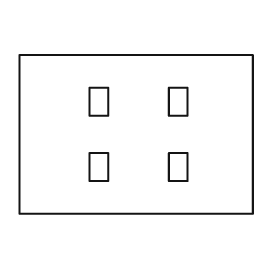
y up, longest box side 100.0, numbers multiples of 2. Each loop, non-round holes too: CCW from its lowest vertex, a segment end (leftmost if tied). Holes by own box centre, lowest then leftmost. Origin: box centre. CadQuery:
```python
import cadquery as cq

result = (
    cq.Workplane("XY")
    .moveTo(-50.0, -34.0)
    .lineTo(50.0, -34.0)
    .lineTo(50.0, 34.0)
    .lineTo(-50.0, 34.0)
    .close()
    .moveTo(-20.0, -20.0)
    .lineTo(-12.0, -20.0)
    .lineTo(-12.0, -8.0)
    .lineTo(-20.0, -8.0)
    .close()
    .moveTo(14.0, -20.0)
    .lineTo(22.0, -20.0)
    .lineTo(22.0, -8.0)
    .lineTo(14.0, -8.0)
    .close()
    .moveTo(-20.0, 8.0)
    .lineTo(-12.0, 8.0)
    .lineTo(-12.0, 20.0)
    .lineTo(-20.0, 20.0)
    .close()
    .moveTo(14.0, 8.0)
    .lineTo(22.0, 8.0)
    .lineTo(22.0, 20.0)
    .lineTo(14.0, 20.0)
    .close()
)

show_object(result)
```